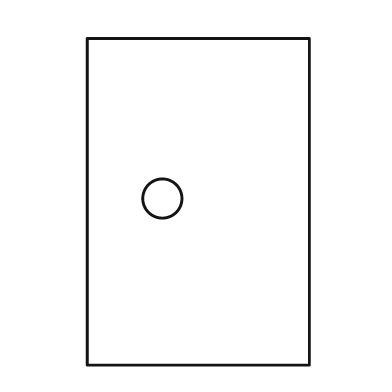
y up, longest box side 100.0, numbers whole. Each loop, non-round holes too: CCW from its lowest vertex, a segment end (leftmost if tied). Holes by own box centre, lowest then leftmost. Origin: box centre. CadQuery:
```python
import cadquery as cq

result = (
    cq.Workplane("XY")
    .moveTo(-34.0, -50.0)
    .lineTo(34.0, -50.0)
    .lineTo(34.0, 50.0)
    .lineTo(-34.0, 50.0)
    .close()
    .moveTo(-11.0, 1.0)
    .circle(6.0)
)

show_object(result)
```